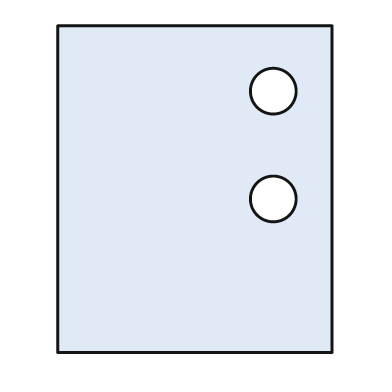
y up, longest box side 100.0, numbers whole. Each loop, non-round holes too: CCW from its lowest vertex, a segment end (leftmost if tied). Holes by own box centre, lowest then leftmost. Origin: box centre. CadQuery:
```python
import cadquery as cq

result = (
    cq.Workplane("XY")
    .moveTo(-42.0, -50.0)
    .lineTo(42.0, -50.0)
    .lineTo(42.0, 50.0)
    .lineTo(-42.0, 50.0)
    .close()
    .moveTo(24.0, -3.0)
    .circle(7.0)
    .moveTo(24.0, 30.0)
    .circle(7.0)
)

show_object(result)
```